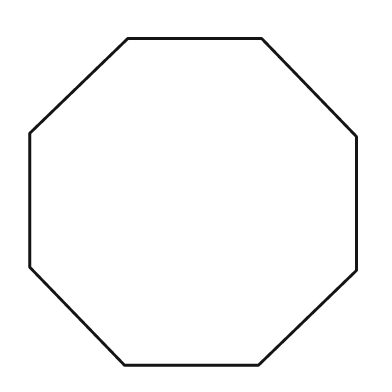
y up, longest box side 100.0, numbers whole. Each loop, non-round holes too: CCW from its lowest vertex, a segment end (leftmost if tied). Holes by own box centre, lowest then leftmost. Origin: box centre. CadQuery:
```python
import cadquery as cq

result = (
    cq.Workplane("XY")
    .moveTo(-21.0, -50.0)
    .lineTo(20.0, -50.0)
    .lineTo(50.0, -21.0)
    .lineTo(50.0, 20.0)
    .lineTo(21.0, 50.0)
    .lineTo(-20.0, 50.0)
    .lineTo(-50.0, 21.0)
    .lineTo(-50.0, -20.0)
    .close()
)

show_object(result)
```